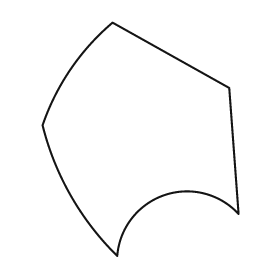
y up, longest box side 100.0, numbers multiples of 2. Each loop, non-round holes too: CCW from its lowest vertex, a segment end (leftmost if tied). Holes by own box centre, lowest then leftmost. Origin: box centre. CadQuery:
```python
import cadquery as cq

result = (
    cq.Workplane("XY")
    .moveTo(-10.0, -50.0)
    .threePointArc((10.0, -24.0), (42.0, -32.0))
    .lineTo(38.0, 22.0)
    .lineTo(-12.0, 50.0)
    .threePointArc((-30.0, 30.0), (-42.0, 6.0))
    .threePointArc((-30.0, -24.0), (-10.0, -50.0))
    .close()
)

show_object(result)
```